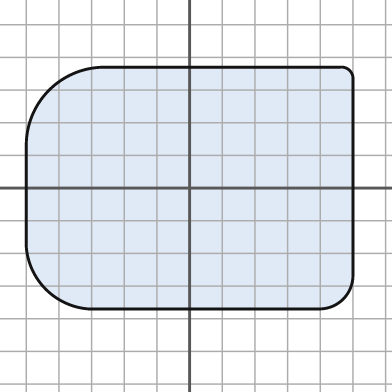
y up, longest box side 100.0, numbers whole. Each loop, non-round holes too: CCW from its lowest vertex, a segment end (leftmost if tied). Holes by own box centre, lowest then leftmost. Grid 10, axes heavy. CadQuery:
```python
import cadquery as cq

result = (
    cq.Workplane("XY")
    .moveTo(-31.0, -37.0)
    .lineTo(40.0, -37.0)
    .threePointArc((47.0, -34.0), (50.0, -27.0))
    .lineTo(50.0, 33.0)
    .threePointArc((49.0, 36.0), (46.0, 37.0))
    .lineTo(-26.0, 37.0)
    .threePointArc((-43.0, 30.0), (-50.0, 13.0))
    .lineTo(-50.0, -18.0)
    .threePointArc((-44.0, -31.0), (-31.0, -37.0))
    .close()
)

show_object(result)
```